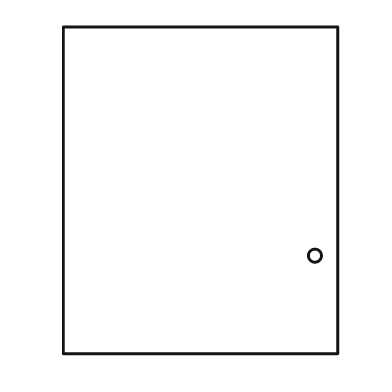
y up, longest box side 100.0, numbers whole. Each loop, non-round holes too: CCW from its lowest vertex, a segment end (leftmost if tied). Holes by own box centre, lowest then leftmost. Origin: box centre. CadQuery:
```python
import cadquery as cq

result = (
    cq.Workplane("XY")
    .moveTo(-42.0, -50.0)
    .lineTo(42.0, -50.0)
    .lineTo(42.0, 50.0)
    .lineTo(-42.0, 50.0)
    .close()
    .moveTo(35.0, -20.0)
    .circle(2.0)
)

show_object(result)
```